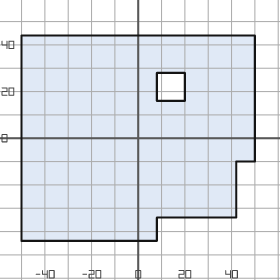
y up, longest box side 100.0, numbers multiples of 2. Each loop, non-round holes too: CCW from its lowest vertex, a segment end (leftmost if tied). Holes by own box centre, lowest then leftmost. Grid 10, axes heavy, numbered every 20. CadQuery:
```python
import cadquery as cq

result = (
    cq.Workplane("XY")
    .moveTo(-50.0, -44.0)
    .lineTo(8.0, -44.0)
    .lineTo(8.0, -34.0)
    .lineTo(42.0, -34.0)
    .lineTo(42.0, -10.0)
    .lineTo(50.0, -10.0)
    .lineTo(50.0, 44.0)
    .lineTo(-50.0, 44.0)
    .close()
    .moveTo(8.0, 16.0)
    .lineTo(20.0, 16.0)
    .lineTo(20.0, 28.0)
    .lineTo(8.0, 28.0)
    .close()
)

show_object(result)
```